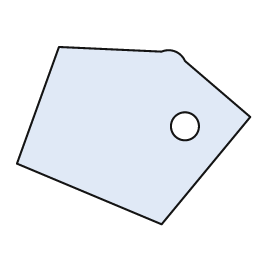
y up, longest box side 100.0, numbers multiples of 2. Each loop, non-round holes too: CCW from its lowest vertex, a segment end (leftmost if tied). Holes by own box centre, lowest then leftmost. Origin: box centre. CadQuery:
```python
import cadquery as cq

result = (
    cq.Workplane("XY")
    .moveTo(12.0, -38.0)
    .lineTo(50.0, 8.0)
    .lineTo(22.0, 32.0)
    .threePointArc((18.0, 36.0), (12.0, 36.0))
    .lineTo(-32.0, 38.0)
    .lineTo(-50.0, -12.0)
    .close()
    .moveTo(22.0, 4.0)
    .circle(6.0)
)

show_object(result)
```